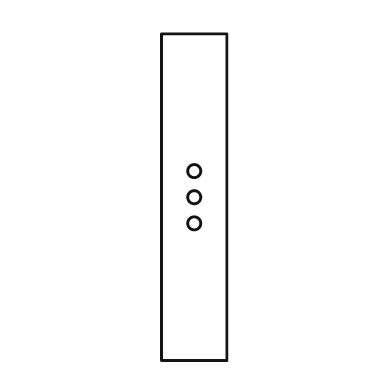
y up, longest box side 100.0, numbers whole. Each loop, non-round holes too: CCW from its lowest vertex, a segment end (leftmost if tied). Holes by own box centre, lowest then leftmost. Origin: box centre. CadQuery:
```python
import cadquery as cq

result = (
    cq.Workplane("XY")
    .moveTo(-10.0, -50.0)
    .lineTo(10.0, -50.0)
    .lineTo(10.0, 50.0)
    .lineTo(-10.0, 50.0)
    .close()
    .moveTo(0.0, -8.0)
    .circle(2.0)
    .moveTo(0.0, 0.0)
    .circle(2.0)
    .moveTo(0.0, 8.0)
    .circle(2.0)
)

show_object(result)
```